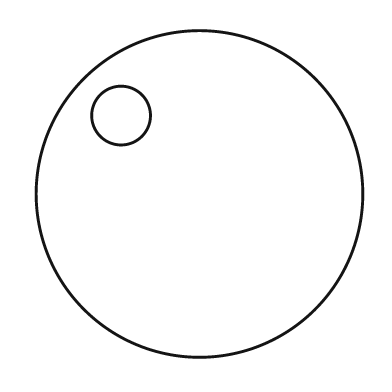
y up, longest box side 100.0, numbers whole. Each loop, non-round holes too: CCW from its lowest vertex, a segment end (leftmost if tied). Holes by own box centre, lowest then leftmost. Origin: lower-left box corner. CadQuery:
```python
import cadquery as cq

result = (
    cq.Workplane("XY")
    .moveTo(50.0, 50.0)
    .circle(50.0)
    .moveTo(26.0, 74.0)
    .circle(9.0)
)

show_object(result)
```